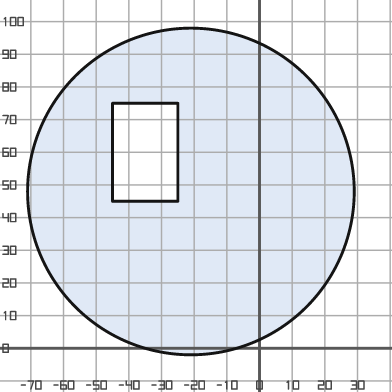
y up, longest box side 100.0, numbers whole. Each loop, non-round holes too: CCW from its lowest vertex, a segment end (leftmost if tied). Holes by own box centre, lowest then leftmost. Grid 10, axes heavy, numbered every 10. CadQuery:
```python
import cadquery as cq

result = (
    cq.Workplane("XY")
    .moveTo(-21.0, 48.0)
    .circle(50.0)
    .moveTo(-45.0, 45.0)
    .lineTo(-25.0, 45.0)
    .lineTo(-25.0, 75.0)
    .lineTo(-45.0, 75.0)
    .close()
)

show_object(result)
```